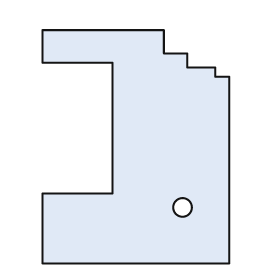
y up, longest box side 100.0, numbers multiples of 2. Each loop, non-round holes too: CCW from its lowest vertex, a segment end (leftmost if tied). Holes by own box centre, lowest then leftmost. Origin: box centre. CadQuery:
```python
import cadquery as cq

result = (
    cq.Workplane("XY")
    .moveTo(-40.0, -50.0)
    .lineTo(40.0, -50.0)
    .lineTo(40.0, 30.0)
    .lineTo(34.0, 30.0)
    .lineTo(34.0, 34.0)
    .lineTo(22.0, 34.0)
    .lineTo(22.0, 40.0)
    .lineTo(12.0, 40.0)
    .lineTo(12.0, 50.0)
    .lineTo(-40.0, 50.0)
    .lineTo(-40.0, 36.0)
    .lineTo(-10.0, 36.0)
    .lineTo(-10.0, -20.0)
    .lineTo(-40.0, -20.0)
    .close()
    .moveTo(20.0, -26.0)
    .circle(4.0)
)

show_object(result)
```